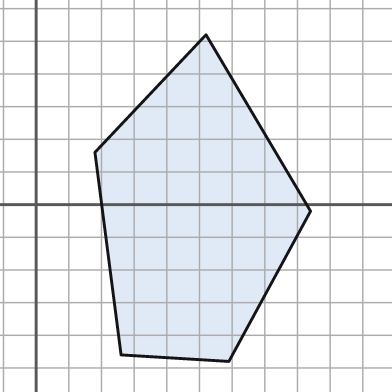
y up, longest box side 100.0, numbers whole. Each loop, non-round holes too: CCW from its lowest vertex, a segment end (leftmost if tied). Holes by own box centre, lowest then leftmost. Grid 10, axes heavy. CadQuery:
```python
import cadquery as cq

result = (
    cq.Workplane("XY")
    .moveTo(59.0, -48.0)
    .lineTo(84.0, -2.0)
    .lineTo(52.0, 52.0)
    .lineTo(18.0, 16.0)
    .lineTo(26.0, -46.0)
    .close()
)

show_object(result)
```